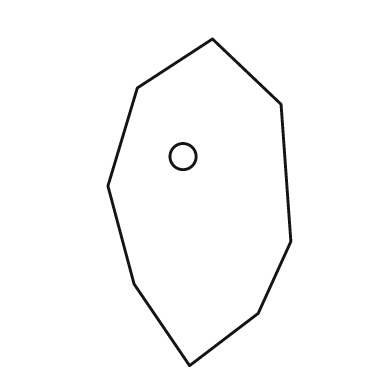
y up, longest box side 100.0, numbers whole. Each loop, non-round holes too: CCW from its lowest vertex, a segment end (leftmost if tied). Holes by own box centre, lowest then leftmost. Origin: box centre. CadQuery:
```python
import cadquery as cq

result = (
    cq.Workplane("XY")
    .moveTo(-3.0, -50.0)
    .lineTo(18.0, -34.0)
    .lineTo(28.0, -12.0)
    .lineTo(25.0, 30.0)
    .lineTo(4.0, 50.0)
    .lineTo(-19.0, 35.0)
    .lineTo(-28.0, 5.0)
    .lineTo(-20.0, -25.0)
    .close()
    .moveTo(-5.0, 14.0)
    .circle(4.0)
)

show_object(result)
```